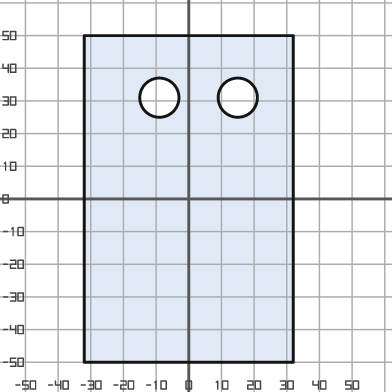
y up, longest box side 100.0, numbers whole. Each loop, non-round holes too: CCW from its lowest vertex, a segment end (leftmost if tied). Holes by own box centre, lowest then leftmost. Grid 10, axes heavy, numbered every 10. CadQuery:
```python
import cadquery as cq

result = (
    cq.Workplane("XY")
    .moveTo(-32.0, -50.0)
    .lineTo(32.0, -50.0)
    .lineTo(32.0, 50.0)
    .lineTo(-32.0, 50.0)
    .close()
    .moveTo(-9.0, 31.0)
    .circle(6.0)
    .moveTo(15.0, 31.0)
    .circle(6.0)
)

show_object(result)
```